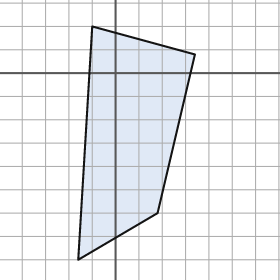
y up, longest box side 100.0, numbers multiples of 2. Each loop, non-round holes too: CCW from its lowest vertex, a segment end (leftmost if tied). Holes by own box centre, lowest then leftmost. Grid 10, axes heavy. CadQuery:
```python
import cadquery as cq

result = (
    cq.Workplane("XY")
    .moveTo(-16.0, -80.0)
    .lineTo(18.0, -60.0)
    .lineTo(34.0, 8.0)
    .lineTo(-10.0, 20.0)
    .close()
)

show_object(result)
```